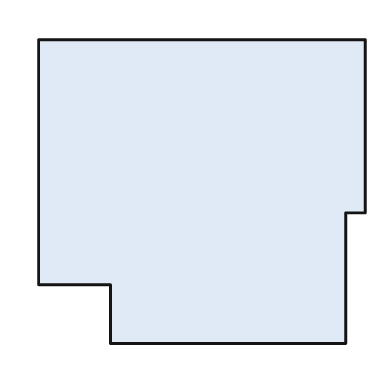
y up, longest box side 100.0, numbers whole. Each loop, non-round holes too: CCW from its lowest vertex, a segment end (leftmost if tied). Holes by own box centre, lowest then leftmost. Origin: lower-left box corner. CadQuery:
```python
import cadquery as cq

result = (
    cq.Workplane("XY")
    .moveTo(22.0, 0.0)
    .lineTo(94.0, 0.0)
    .lineTo(94.0, 40.0)
    .lineTo(100.0, 40.0)
    .lineTo(100.0, 93.0)
    .lineTo(0.0, 93.0)
    .lineTo(0.0, 18.0)
    .lineTo(22.0, 18.0)
    .close()
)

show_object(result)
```